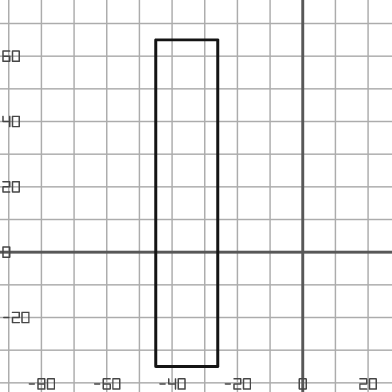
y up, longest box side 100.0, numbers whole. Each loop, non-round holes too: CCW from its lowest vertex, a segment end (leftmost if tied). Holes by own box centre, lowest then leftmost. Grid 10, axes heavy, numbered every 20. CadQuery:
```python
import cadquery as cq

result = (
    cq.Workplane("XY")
    .moveTo(-45.0, -35.0)
    .lineTo(-26.0, -35.0)
    .lineTo(-26.0, 65.0)
    .lineTo(-45.0, 65.0)
    .close()
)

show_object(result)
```